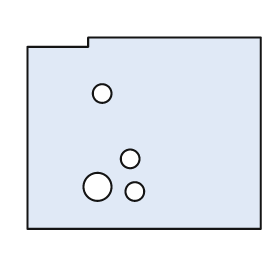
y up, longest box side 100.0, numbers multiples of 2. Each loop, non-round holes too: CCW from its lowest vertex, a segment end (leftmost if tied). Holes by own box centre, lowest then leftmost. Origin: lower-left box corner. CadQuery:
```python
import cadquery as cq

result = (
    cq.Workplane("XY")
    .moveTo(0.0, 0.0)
    .lineTo(100.0, 0.0)
    .lineTo(100.0, 82.0)
    .lineTo(26.0, 82.0)
    .lineTo(26.0, 78.0)
    .lineTo(0.0, 78.0)
    .close()
    .moveTo(46.0, 16.0)
    .circle(4.0)
    .moveTo(30.0, 18.0)
    .circle(6.0)
    .moveTo(44.0, 30.0)
    .circle(4.0)
    .moveTo(32.0, 58.0)
    .circle(4.0)
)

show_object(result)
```